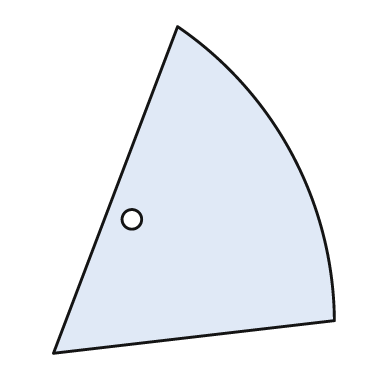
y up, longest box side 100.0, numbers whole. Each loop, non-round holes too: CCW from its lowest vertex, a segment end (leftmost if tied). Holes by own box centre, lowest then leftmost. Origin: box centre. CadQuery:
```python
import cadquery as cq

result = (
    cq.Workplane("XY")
    .moveTo(-43.0, -50.0)
    .lineTo(43.0, -40.0)
    .threePointArc((30.0, 11.0), (-5.0, 50.0))
    .close()
    .moveTo(-19.0, -9.0)
    .circle(3.0)
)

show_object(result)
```